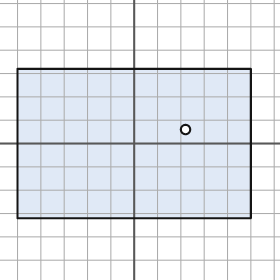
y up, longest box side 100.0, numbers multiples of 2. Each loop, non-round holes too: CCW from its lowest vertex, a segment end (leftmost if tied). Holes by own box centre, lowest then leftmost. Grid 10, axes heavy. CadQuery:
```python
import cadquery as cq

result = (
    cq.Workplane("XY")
    .moveTo(-50.0, -32.0)
    .lineTo(50.0, -32.0)
    .lineTo(50.0, 32.0)
    .lineTo(-50.0, 32.0)
    .close()
    .moveTo(22.0, 6.0)
    .circle(2.0)
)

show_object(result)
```